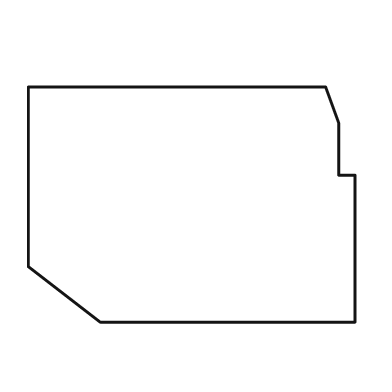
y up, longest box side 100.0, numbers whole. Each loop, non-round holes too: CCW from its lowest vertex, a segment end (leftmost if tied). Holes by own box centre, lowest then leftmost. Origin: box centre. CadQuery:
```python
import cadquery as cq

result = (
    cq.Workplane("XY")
    .moveTo(-28.0, -36.0)
    .lineTo(50.0, -36.0)
    .lineTo(50.0, 9.0)
    .lineTo(45.0, 9.0)
    .lineTo(45.0, 25.0)
    .lineTo(41.0, 36.0)
    .lineTo(-50.0, 36.0)
    .lineTo(-50.0, -19.0)
    .close()
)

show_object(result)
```